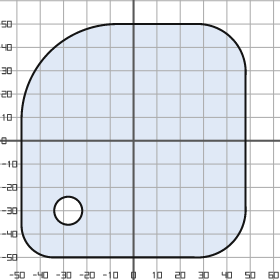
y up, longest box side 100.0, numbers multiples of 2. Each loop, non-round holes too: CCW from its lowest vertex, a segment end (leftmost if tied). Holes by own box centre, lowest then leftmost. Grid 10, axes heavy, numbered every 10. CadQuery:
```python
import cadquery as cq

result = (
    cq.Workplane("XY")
    .moveTo(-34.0, -50.0)
    .lineTo(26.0, -50.0)
    .threePointArc((42.0, -44.0), (48.0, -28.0))
    .lineTo(48.0, 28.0)
    .threePointArc((42.0, 44.0), (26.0, 50.0))
    .lineTo(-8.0, 50.0)
    .threePointArc((-36.0, 38.0), (-48.0, 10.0))
    .lineTo(-48.0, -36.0)
    .threePointArc((-44.0, -46.0), (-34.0, -50.0))
    .close()
    .moveTo(-28.0, -30.0)
    .circle(6.0)
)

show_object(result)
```